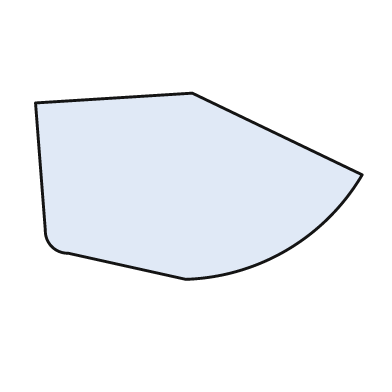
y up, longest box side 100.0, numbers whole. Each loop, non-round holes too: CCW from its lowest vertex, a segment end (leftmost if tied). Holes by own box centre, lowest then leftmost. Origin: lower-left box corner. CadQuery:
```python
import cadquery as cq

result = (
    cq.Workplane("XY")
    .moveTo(46.0, 0.0)
    .threePointArc((77.0, 9.0), (100.0, 32.0))
    .lineTo(48.0, 57.0)
    .lineTo(0.0, 54.0)
    .lineTo(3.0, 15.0)
    .threePointArc((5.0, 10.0), (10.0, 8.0))
    .close()
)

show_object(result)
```